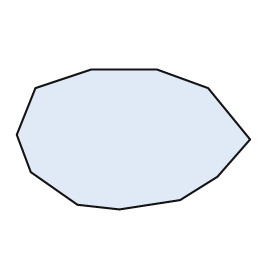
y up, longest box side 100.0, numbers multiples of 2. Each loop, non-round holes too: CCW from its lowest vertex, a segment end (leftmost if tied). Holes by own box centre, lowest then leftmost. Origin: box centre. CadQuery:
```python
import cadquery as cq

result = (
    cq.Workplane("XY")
    .moveTo(-6.0, -30.0)
    .lineTo(20.0, -26.0)
    .lineTo(36.0, -16.0)
    .lineTo(50.0, 0.0)
    .lineTo(32.0, 22.0)
    .lineTo(10.0, 30.0)
    .lineTo(-18.0, 30.0)
    .lineTo(-42.0, 22.0)
    .lineTo(-50.0, 2.0)
    .lineTo(-44.0, -14.0)
    .lineTo(-24.0, -28.0)
    .close()
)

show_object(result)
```